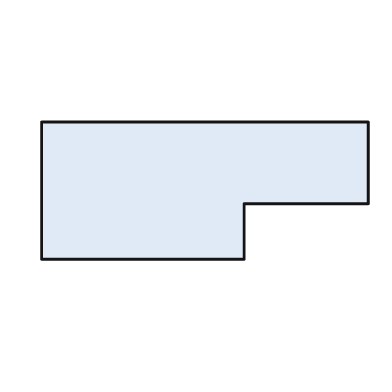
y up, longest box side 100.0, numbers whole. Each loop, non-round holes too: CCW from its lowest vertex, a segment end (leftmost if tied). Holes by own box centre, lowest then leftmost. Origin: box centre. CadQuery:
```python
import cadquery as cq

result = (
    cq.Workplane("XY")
    .moveTo(-50.0, -21.0)
    .lineTo(12.0, -21.0)
    .lineTo(12.0, -4.0)
    .lineTo(50.0, -4.0)
    .lineTo(50.0, 21.0)
    .lineTo(-50.0, 21.0)
    .close()
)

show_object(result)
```